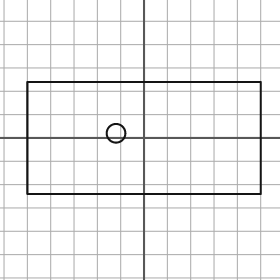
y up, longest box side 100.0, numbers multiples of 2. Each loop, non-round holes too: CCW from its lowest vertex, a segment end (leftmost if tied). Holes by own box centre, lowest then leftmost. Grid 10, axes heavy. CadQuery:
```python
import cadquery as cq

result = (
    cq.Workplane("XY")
    .moveTo(-50.0, -24.0)
    .lineTo(50.0, -24.0)
    .lineTo(50.0, 24.0)
    .lineTo(-50.0, 24.0)
    .close()
    .moveTo(-12.0, 2.0)
    .circle(4.0)
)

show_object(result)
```